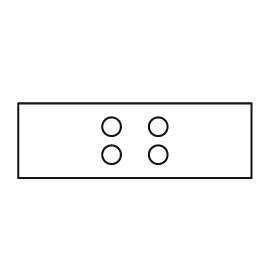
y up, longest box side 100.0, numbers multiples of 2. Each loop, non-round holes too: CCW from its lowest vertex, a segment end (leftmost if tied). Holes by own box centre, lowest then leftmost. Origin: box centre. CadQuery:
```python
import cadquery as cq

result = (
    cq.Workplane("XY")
    .moveTo(-50.0, -16.0)
    .lineTo(50.0, -16.0)
    .lineTo(50.0, 16.0)
    .lineTo(-50.0, 16.0)
    .close()
    .moveTo(-10.0, -6.0)
    .circle(4.0)
    .moveTo(10.0, -6.0)
    .circle(4.0)
    .moveTo(-10.0, 6.0)
    .circle(4.0)
    .moveTo(10.0, 6.0)
    .circle(4.0)
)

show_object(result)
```